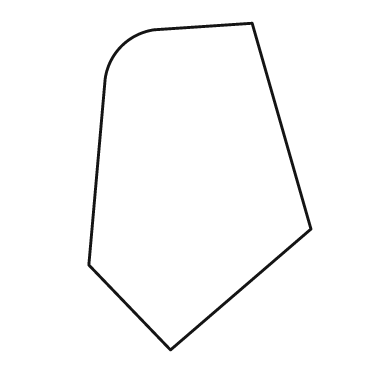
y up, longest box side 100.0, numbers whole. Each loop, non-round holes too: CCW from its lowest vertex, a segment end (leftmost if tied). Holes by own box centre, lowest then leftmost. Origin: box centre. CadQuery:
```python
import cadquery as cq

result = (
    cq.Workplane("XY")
    .moveTo(-9.0, -50.0)
    .lineTo(34.0, -13.0)
    .lineTo(16.0, 50.0)
    .lineTo(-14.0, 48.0)
    .threePointArc((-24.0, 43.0), (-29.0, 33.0))
    .lineTo(-34.0, -24.0)
    .close()
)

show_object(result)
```